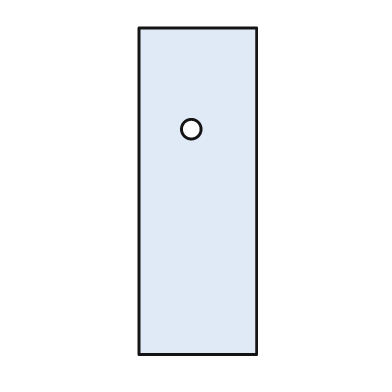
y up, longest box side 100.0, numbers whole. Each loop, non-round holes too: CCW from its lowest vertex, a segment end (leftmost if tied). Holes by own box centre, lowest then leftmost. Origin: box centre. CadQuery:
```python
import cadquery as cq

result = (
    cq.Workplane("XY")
    .moveTo(-18.0, -50.0)
    .lineTo(18.0, -50.0)
    .lineTo(18.0, 50.0)
    .lineTo(-18.0, 50.0)
    .close()
    .moveTo(-2.0, 19.0)
    .circle(3.0)
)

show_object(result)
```